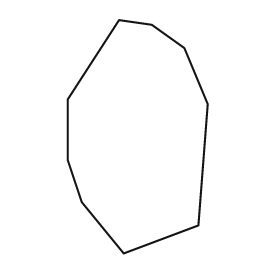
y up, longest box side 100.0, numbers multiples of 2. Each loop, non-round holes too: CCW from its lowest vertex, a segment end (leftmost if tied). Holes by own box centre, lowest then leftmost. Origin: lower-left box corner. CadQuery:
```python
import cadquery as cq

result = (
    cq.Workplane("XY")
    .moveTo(24.0, 0.0)
    .lineTo(56.0, 12.0)
    .lineTo(60.0, 64.0)
    .lineTo(50.0, 88.0)
    .lineTo(36.0, 98.0)
    .lineTo(22.0, 100.0)
    .lineTo(0.0, 66.0)
    .lineTo(0.0, 40.0)
    .lineTo(6.0, 22.0)
    .close()
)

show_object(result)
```